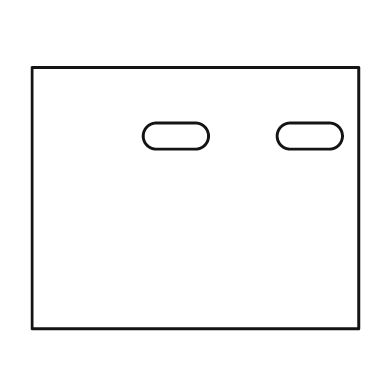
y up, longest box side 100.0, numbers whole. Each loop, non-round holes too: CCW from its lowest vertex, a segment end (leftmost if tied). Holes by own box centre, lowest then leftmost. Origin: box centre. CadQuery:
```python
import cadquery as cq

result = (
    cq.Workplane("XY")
    .moveTo(-50.0, -40.0)
    .lineTo(50.0, -40.0)
    .lineTo(50.0, 40.0)
    .lineTo(-50.0, 40.0)
    .close()
    .moveTo(-12.0, 15.0)
    .lineTo(0.0, 15.0)
    .threePointArc((4.0, 19.0), (0.0, 23.0))
    .lineTo(-12.0, 23.0)
    .threePointArc((-16.0, 19.0), (-12.0, 15.0))
    .close()
    .moveTo(29.0, 15.0)
    .lineTo(41.0, 15.0)
    .threePointArc((45.0, 19.0), (41.0, 23.0))
    .lineTo(29.0, 23.0)
    .threePointArc((25.0, 19.0), (29.0, 15.0))
    .close()
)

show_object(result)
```